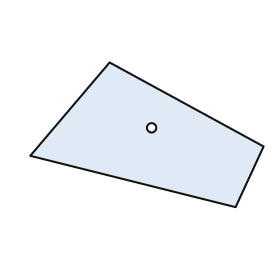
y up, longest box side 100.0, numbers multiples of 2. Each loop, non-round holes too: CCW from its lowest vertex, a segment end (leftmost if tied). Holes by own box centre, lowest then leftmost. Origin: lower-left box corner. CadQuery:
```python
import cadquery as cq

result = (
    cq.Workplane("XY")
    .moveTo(88.0, 0.0)
    .lineTo(100.0, 26.0)
    .lineTo(34.0, 62.0)
    .lineTo(0.0, 22.0)
    .close()
    .moveTo(52.0, 34.0)
    .circle(2.0)
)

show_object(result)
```